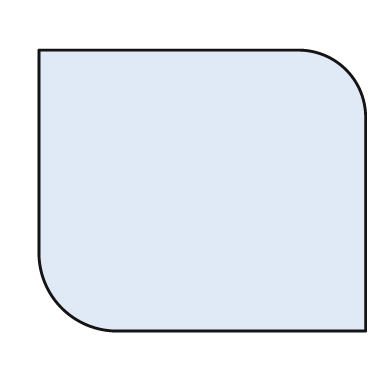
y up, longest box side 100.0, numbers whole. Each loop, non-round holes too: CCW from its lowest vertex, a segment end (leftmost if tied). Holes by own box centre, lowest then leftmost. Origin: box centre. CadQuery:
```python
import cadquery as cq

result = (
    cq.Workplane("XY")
    .moveTo(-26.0, -43.0)
    .lineTo(50.0, -43.0)
    .lineTo(50.0, 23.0)
    .threePointArc((44.0, 37.0), (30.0, 43.0))
    .lineTo(-50.0, 43.0)
    .lineTo(-50.0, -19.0)
    .threePointArc((-43.0, -36.0), (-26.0, -43.0))
    .close()
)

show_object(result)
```